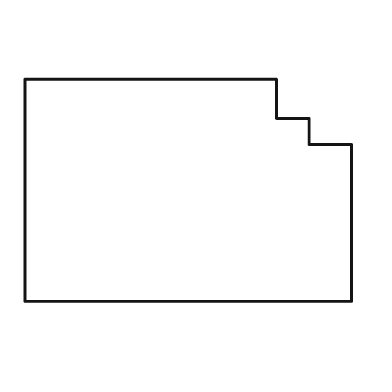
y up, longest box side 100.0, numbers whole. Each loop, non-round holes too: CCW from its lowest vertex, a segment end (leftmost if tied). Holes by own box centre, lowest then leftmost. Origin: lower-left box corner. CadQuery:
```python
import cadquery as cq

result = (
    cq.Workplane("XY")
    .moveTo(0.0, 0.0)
    .lineTo(100.0, 0.0)
    .lineTo(100.0, 48.0)
    .lineTo(87.0, 48.0)
    .lineTo(87.0, 56.0)
    .lineTo(77.0, 56.0)
    .lineTo(77.0, 68.0)
    .lineTo(0.0, 68.0)
    .close()
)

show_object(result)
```